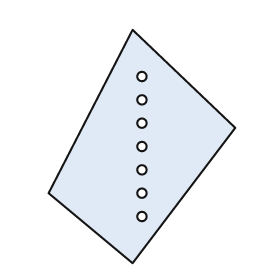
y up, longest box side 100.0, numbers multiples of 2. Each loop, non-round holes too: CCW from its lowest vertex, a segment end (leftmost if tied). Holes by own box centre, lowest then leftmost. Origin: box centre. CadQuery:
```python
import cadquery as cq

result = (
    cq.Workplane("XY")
    .moveTo(-4.0, -50.0)
    .lineTo(40.0, 8.0)
    .lineTo(-4.0, 50.0)
    .lineTo(-40.0, -20.0)
    .close()
    .moveTo(0.0, -30.0)
    .circle(2.0)
    .moveTo(0.0, -20.0)
    .circle(2.0)
    .moveTo(0.0, -10.0)
    .circle(2.0)
    .moveTo(0.0, 0.0)
    .circle(2.0)
    .moveTo(0.0, 10.0)
    .circle(2.0)
    .moveTo(0.0, 20.0)
    .circle(2.0)
    .moveTo(0.0, 30.0)
    .circle(2.0)
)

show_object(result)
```